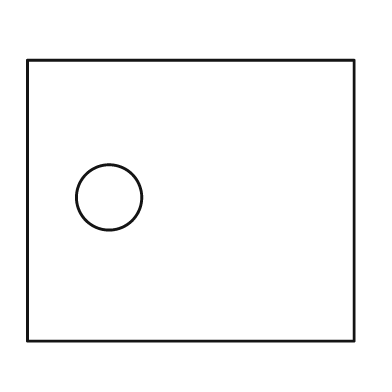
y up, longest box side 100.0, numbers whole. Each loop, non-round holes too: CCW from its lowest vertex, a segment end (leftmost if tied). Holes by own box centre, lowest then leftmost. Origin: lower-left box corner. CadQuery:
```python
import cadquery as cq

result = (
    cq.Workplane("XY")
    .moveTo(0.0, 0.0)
    .lineTo(100.0, 0.0)
    .lineTo(100.0, 86.0)
    .lineTo(0.0, 86.0)
    .close()
    .moveTo(25.0, 44.0)
    .circle(10.0)
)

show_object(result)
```